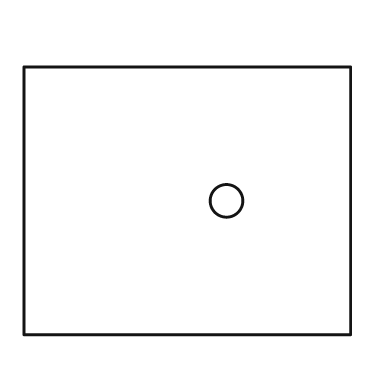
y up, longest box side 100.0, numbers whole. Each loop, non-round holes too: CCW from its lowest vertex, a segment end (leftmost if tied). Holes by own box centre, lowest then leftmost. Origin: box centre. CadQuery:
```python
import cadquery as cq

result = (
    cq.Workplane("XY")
    .moveTo(-50.0, -41.0)
    .lineTo(50.0, -41.0)
    .lineTo(50.0, 41.0)
    .lineTo(-50.0, 41.0)
    .close()
    .moveTo(12.0, 0.0)
    .circle(5.0)
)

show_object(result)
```